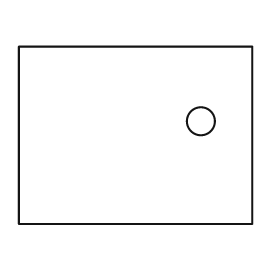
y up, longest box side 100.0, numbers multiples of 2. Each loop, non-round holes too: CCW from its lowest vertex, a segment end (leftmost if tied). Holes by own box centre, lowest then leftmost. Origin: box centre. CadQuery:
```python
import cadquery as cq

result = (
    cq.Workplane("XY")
    .moveTo(-50.0, -38.0)
    .lineTo(50.0, -38.0)
    .lineTo(50.0, 38.0)
    .lineTo(-50.0, 38.0)
    .close()
    .moveTo(28.0, 6.0)
    .circle(6.0)
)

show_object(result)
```